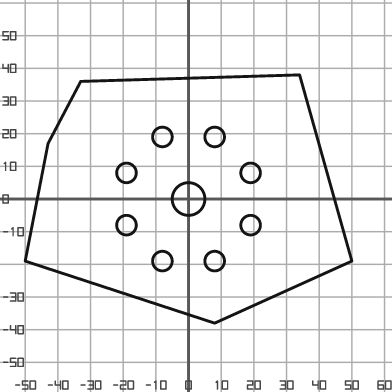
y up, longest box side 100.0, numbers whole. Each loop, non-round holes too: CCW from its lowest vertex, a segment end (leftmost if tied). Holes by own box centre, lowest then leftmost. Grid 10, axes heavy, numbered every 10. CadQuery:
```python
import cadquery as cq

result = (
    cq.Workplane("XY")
    .moveTo(8.0, -38.0)
    .lineTo(50.0, -19.0)
    .lineTo(34.0, 38.0)
    .lineTo(-33.0, 36.0)
    .lineTo(-43.0, 17.0)
    .lineTo(-50.0, -19.0)
    .close()
    .moveTo(-8.0, -19.0)
    .circle(3.0)
    .moveTo(8.0, -19.0)
    .circle(3.0)
    .moveTo(-19.0, -8.0)
    .circle(3.0)
    .moveTo(19.0, -8.0)
    .circle(3.0)
    .moveTo(0.0, 0.0)
    .circle(5.0)
    .moveTo(-19.0, 8.0)
    .circle(3.0)
    .moveTo(19.0, 8.0)
    .circle(3.0)
    .moveTo(-8.0, 19.0)
    .circle(3.0)
    .moveTo(8.0, 19.0)
    .circle(3.0)
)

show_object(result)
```